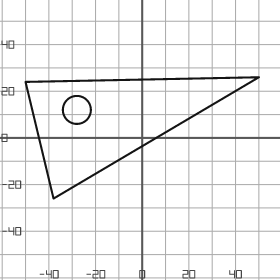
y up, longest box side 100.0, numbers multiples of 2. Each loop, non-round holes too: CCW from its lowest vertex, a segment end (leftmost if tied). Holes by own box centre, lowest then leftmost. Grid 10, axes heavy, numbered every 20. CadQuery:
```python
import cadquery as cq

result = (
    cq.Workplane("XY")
    .moveTo(-38.0, -26.0)
    .lineTo(50.0, 26.0)
    .lineTo(-50.0, 24.0)
    .close()
    .moveTo(-28.0, 12.0)
    .circle(6.0)
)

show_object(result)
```